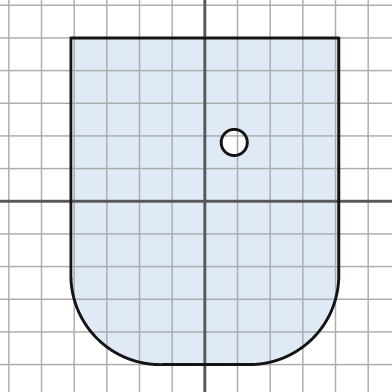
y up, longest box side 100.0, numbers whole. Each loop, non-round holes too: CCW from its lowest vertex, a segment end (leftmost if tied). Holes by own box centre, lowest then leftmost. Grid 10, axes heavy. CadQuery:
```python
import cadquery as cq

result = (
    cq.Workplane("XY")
    .moveTo(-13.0, -50.0)
    .lineTo(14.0, -50.0)
    .threePointArc((33.0, -42.0), (41.0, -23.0))
    .lineTo(41.0, 50.0)
    .lineTo(-41.0, 50.0)
    .lineTo(-41.0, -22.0)
    .threePointArc((-33.0, -42.0), (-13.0, -50.0))
    .close()
    .moveTo(9.0, 18.0)
    .circle(4.0)
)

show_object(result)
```